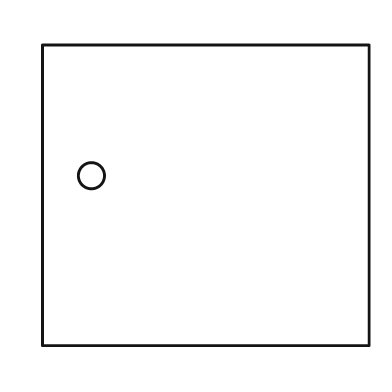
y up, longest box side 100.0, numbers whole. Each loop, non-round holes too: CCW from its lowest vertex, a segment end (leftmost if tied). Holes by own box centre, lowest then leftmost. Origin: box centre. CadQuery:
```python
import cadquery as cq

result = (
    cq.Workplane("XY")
    .moveTo(-50.0, -46.0)
    .lineTo(50.0, -46.0)
    .lineTo(50.0, 46.0)
    .lineTo(-50.0, 46.0)
    .close()
    .moveTo(-35.0, 6.0)
    .circle(4.0)
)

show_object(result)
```